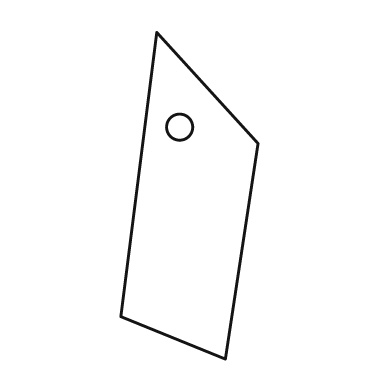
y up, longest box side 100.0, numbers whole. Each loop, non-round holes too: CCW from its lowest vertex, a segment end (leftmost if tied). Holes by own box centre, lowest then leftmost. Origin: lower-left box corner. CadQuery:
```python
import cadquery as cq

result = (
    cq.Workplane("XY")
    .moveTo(32.0, 0.0)
    .lineTo(42.0, 66.0)
    .lineTo(11.0, 100.0)
    .lineTo(0.0, 13.0)
    .close()
    .moveTo(18.0, 71.0)
    .circle(4.0)
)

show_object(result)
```